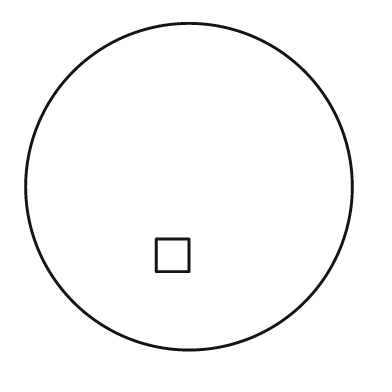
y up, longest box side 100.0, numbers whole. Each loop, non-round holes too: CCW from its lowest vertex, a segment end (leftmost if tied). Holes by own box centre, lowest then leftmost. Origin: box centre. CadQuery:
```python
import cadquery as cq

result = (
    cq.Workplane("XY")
    .moveTo(0.0, 0.0)
    .circle(50.0)
    .moveTo(-10.0, -26.0)
    .lineTo(0.0, -26.0)
    .lineTo(0.0, -16.0)
    .lineTo(-10.0, -16.0)
    .close()
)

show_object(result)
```